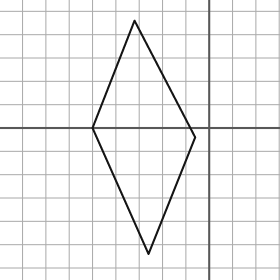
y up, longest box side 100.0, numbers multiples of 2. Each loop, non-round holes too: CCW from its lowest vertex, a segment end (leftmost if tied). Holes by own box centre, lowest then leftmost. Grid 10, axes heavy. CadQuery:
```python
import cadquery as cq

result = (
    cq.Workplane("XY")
    .moveTo(-26.0, -54.0)
    .lineTo(-6.0, -4.0)
    .lineTo(-32.0, 46.0)
    .lineTo(-50.0, 0.0)
    .close()
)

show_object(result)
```